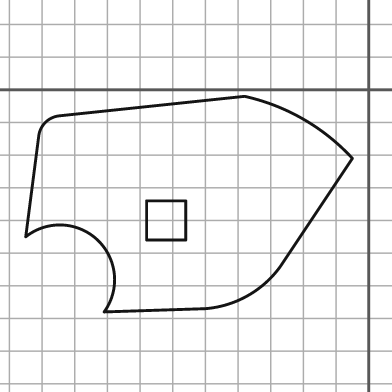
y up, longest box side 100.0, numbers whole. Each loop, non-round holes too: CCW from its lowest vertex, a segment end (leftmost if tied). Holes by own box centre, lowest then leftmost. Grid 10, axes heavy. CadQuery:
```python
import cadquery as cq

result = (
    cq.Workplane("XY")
    .moveTo(-81.0, -68.0)
    .lineTo(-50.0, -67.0)
    .threePointArc((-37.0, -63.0), (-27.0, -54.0))
    .lineTo(-5.0, -21.0)
    .threePointArc((-20.0, -9.0), (-38.0, -2.0))
    .lineTo(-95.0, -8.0)
    .threePointArc((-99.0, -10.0), (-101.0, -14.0))
    .lineTo(-105.0, -45.0)
    .threePointArc((-83.0, -46.0), (-81.0, -68.0))
    .close()
    .moveTo(-68.0, -46.0)
    .lineTo(-56.0, -46.0)
    .lineTo(-56.0, -34.0)
    .lineTo(-68.0, -34.0)
    .close()
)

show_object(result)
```